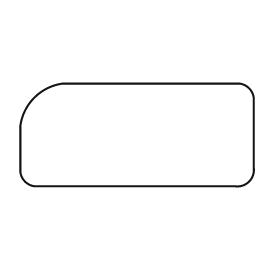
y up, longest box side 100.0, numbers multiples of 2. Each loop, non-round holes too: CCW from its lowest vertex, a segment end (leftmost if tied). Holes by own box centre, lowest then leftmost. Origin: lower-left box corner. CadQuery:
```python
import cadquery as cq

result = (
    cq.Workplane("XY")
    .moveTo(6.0, 0.0)
    .lineTo(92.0, 0.0)
    .threePointArc((98.0, 2.0), (100.0, 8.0))
    .lineTo(100.0, 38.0)
    .threePointArc((98.0, 42.0), (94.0, 44.0))
    .lineTo(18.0, 44.0)
    .threePointArc((6.0, 38.0), (0.0, 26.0))
    .lineTo(0.0, 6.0)
    .threePointArc((2.0, 2.0), (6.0, 0.0))
    .close()
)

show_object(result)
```